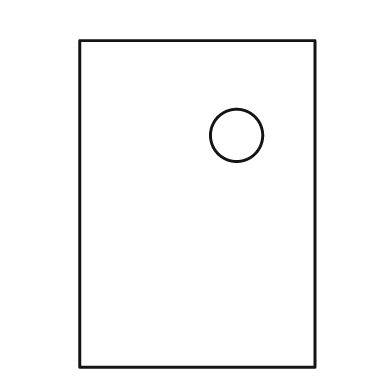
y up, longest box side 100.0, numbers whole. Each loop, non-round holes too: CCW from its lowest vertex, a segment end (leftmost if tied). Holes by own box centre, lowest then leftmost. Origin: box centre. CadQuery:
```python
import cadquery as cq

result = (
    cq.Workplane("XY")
    .moveTo(-36.0, -50.0)
    .lineTo(36.0, -50.0)
    .lineTo(36.0, 50.0)
    .lineTo(-36.0, 50.0)
    .close()
    .moveTo(12.0, 21.0)
    .circle(8.0)
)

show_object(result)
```